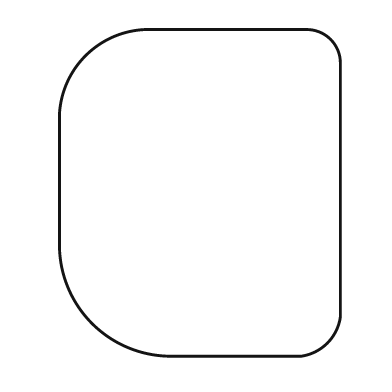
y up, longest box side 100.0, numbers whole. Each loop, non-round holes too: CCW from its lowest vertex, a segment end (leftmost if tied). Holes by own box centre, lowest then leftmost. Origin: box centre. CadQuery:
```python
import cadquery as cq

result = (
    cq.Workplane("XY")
    .moveTo(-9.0, -50.0)
    .lineTo(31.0, -50.0)
    .threePointArc((39.0, -46.0), (43.0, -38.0))
    .lineTo(43.0, 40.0)
    .threePointArc((40.0, 47.0), (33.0, 50.0))
    .lineTo(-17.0, 50.0)
    .threePointArc((-35.0, 42.0), (-43.0, 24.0))
    .lineTo(-43.0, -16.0)
    .threePointArc((-33.0, -40.0), (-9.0, -50.0))
    .close()
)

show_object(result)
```